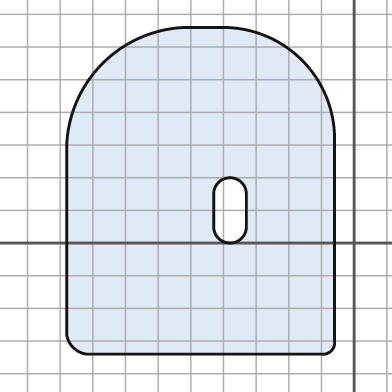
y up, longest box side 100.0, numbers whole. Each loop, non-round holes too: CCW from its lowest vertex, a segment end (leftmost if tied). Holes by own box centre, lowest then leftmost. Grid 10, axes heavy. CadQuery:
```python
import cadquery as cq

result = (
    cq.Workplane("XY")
    .moveTo(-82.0, -34.0)
    .lineTo(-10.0, -34.0)
    .threePointArc((-7.0, -33.0), (-6.0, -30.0))
    .lineTo(-6.0, 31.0)
    .threePointArc((-16.0, 56.0), (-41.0, 66.0))
    .lineTo(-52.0, 66.0)
    .threePointArc((-77.0, 55.0), (-88.0, 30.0))
    .lineTo(-88.0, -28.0)
    .threePointArc((-86.0, -32.0), (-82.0, -34.0))
    .close()
    .moveTo(-43.0, 5.0)
    .threePointArc((-38.0, 0.0), (-33.0, 5.0))
    .lineTo(-33.0, 15.0)
    .threePointArc((-38.0, 20.0), (-43.0, 15.0))
    .close()
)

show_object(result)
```